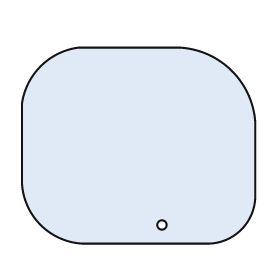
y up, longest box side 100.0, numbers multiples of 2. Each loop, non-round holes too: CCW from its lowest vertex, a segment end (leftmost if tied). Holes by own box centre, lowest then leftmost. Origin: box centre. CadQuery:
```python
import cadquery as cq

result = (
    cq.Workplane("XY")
    .moveTo(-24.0, -42.0)
    .lineTo(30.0, -42.0)
    .threePointArc((44.0, -36.0), (50.0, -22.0))
    .lineTo(50.0, 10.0)
    .threePointArc((40.0, 32.0), (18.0, 42.0))
    .lineTo(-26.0, 42.0)
    .threePointArc((-42.0, 34.0), (-50.0, 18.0))
    .lineTo(-50.0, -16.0)
    .threePointArc((-42.0, -34.0), (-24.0, -42.0))
    .close()
    .moveTo(10.0, -34.0)
    .circle(2.0)
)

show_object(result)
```